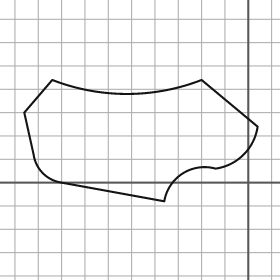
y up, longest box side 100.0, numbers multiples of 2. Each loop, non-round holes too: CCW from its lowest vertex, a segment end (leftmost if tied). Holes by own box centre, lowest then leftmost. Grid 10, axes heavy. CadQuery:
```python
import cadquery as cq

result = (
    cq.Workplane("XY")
    .moveTo(-36.0, -8.0)
    .threePointArc((-28.0, 4.0), (-14.0, 6.0))
    .threePointArc((-2.0, 12.0), (4.0, 24.0))
    .lineTo(-20.0, 44.0)
    .threePointArc((-52.0, 38.0), (-84.0, 44.0))
    .lineTo(-96.0, 30.0)
    .lineTo(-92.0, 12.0)
    .threePointArc((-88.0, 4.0), (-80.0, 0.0))
    .close()
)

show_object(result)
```